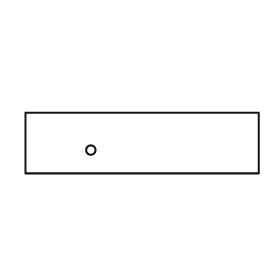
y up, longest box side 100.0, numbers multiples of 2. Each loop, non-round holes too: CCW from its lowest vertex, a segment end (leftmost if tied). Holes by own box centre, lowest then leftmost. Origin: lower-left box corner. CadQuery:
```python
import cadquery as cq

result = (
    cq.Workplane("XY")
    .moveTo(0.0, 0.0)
    .lineTo(100.0, 0.0)
    .lineTo(100.0, 26.0)
    .lineTo(0.0, 26.0)
    .close()
    .moveTo(28.0, 10.0)
    .circle(2.0)
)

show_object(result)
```